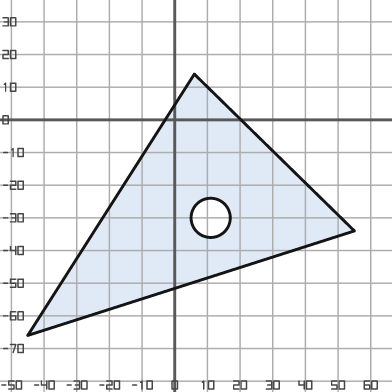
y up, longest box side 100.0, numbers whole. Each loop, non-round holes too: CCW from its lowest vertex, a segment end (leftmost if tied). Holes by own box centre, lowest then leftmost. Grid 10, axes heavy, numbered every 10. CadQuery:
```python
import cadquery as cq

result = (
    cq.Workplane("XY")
    .moveTo(-45.0, -66.0)
    .lineTo(55.0, -34.0)
    .lineTo(6.0, 14.0)
    .close()
    .moveTo(11.0, -30.0)
    .circle(6.0)
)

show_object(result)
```